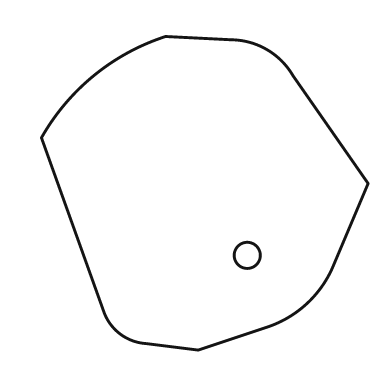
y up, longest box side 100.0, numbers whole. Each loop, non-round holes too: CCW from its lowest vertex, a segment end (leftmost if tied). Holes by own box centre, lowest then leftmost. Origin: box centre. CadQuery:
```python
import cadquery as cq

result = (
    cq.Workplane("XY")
    .moveTo(-2.0, -48.0)
    .lineTo(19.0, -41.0)
    .threePointArc((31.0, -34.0), (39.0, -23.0))
    .lineTo(50.0, 3.0)
    .lineTo(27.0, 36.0)
    .threePointArc((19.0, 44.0), (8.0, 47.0))
    .lineTo(-12.0, 48.0)
    .threePointArc((-34.0, 36.0), (-50.0, 17.0))
    .lineTo(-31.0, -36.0)
    .threePointArc((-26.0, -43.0), (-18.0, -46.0))
    .close()
    .moveTo(13.0, -19.0)
    .circle(4.0)
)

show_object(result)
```